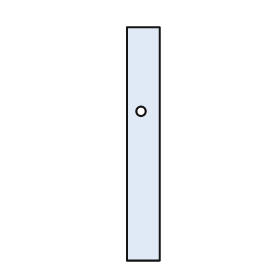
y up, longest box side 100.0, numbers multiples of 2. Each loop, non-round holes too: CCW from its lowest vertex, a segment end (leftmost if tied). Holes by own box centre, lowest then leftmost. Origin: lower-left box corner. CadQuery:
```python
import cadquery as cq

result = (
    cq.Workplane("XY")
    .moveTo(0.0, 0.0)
    .lineTo(14.0, 0.0)
    .lineTo(14.0, 100.0)
    .lineTo(0.0, 100.0)
    .close()
    .moveTo(6.0, 64.0)
    .circle(2.0)
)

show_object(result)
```